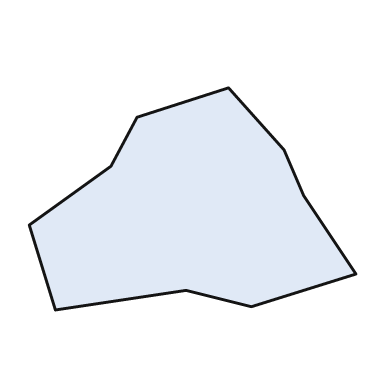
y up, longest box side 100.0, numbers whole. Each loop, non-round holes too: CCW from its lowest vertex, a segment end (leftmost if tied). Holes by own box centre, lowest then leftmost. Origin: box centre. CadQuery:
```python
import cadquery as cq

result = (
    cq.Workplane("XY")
    .moveTo(-42.0, -34.0)
    .lineTo(-2.0, -28.0)
    .lineTo(18.0, -33.0)
    .lineTo(50.0, -23.0)
    .lineTo(34.0, 1.0)
    .lineTo(28.0, 15.0)
    .lineTo(11.0, 34.0)
    .lineTo(-17.0, 25.0)
    .lineTo(-25.0, 10.0)
    .lineTo(-50.0, -8.0)
    .close()
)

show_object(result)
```